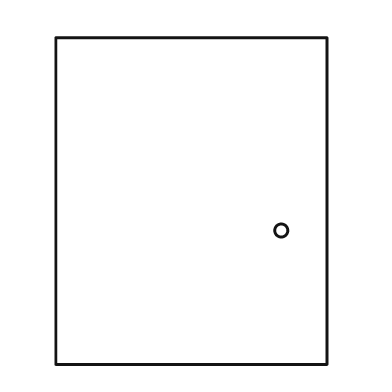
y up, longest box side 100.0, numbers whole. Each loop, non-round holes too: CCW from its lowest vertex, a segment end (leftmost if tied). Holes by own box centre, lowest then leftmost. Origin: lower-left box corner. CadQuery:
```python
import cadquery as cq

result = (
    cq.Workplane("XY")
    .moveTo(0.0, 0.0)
    .lineTo(83.0, 0.0)
    .lineTo(83.0, 100.0)
    .lineTo(0.0, 100.0)
    .close()
    .moveTo(69.0, 41.0)
    .circle(2.0)
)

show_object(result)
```